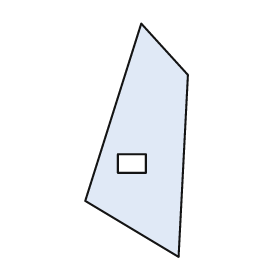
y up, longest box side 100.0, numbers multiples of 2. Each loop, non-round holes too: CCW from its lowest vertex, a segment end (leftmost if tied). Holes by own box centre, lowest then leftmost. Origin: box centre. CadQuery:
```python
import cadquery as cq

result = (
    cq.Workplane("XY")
    .moveTo(18.0, -50.0)
    .lineTo(22.0, 28.0)
    .lineTo(2.0, 50.0)
    .lineTo(-22.0, -26.0)
    .close()
    .moveTo(-8.0, -14.0)
    .lineTo(4.0, -14.0)
    .lineTo(4.0, -6.0)
    .lineTo(-8.0, -6.0)
    .close()
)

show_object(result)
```